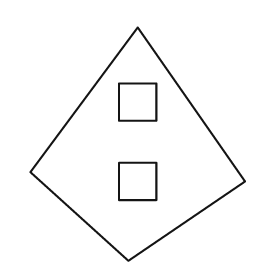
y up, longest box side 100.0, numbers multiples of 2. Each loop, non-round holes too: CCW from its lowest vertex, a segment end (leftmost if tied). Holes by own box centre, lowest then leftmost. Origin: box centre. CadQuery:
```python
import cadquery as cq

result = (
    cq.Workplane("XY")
    .moveTo(-4.0, -50.0)
    .lineTo(46.0, -16.0)
    .lineTo(0.0, 50.0)
    .lineTo(-46.0, -12.0)
    .close()
    .moveTo(-8.0, -24.0)
    .lineTo(8.0, -24.0)
    .lineTo(8.0, -8.0)
    .lineTo(-8.0, -8.0)
    .close()
    .moveTo(-8.0, 10.0)
    .lineTo(8.0, 10.0)
    .lineTo(8.0, 26.0)
    .lineTo(-8.0, 26.0)
    .close()
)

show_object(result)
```